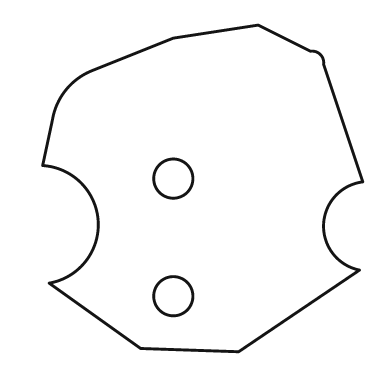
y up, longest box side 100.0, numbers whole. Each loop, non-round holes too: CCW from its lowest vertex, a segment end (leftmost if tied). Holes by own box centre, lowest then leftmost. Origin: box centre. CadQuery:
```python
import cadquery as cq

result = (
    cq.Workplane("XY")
    .moveTo(11.0, -50.0)
    .lineTo(48.0, -25.0)
    .threePointArc((37.0, -11.0), (49.0, 2.0))
    .lineTo(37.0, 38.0)
    .threePointArc((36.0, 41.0), (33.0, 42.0))
    .lineTo(17.0, 50.0)
    .lineTo(-9.0, 46.0)
    .lineTo(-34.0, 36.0)
    .threePointArc((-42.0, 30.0), (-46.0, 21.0))
    .lineTo(-49.0, 7.0)
    .threePointArc((-32.0, -10.0), (-47.0, -29.0))
    .lineTo(-19.0, -49.0)
    .close()
    .moveTo(-9.0, -33.0)
    .circle(6.0)
    .moveTo(-9.0, 3.0)
    .circle(6.0)
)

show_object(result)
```